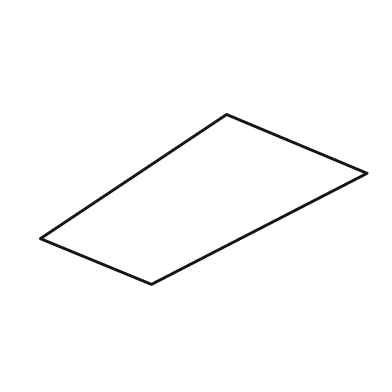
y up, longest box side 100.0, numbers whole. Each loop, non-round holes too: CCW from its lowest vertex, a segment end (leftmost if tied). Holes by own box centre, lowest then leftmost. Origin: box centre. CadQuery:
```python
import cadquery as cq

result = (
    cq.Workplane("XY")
    .moveTo(-16.0, -26.0)
    .lineTo(50.0, 8.0)
    .lineTo(7.0, 26.0)
    .lineTo(-50.0, -12.0)
    .close()
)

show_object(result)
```